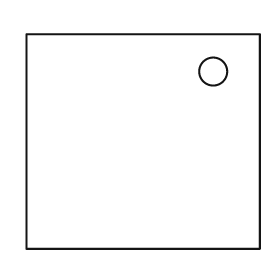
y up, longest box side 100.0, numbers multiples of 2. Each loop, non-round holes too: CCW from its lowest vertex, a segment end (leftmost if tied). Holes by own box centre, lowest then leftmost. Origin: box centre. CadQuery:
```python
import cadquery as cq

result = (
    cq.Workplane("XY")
    .moveTo(-50.0, -46.0)
    .lineTo(50.0, -46.0)
    .lineTo(50.0, 46.0)
    .lineTo(-50.0, 46.0)
    .close()
    .moveTo(30.0, 30.0)
    .circle(6.0)
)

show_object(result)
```